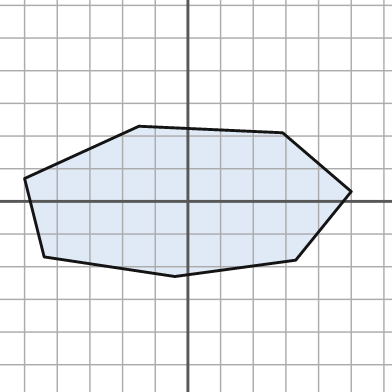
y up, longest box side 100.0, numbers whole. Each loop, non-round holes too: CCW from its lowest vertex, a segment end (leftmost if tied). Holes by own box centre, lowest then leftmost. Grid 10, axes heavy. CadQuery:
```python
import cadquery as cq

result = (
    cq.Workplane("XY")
    .moveTo(-4.0, -23.0)
    .lineTo(33.0, -18.0)
    .lineTo(50.0, 3.0)
    .lineTo(29.0, 21.0)
    .lineTo(-15.0, 23.0)
    .lineTo(-50.0, 7.0)
    .lineTo(-44.0, -17.0)
    .close()
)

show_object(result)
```